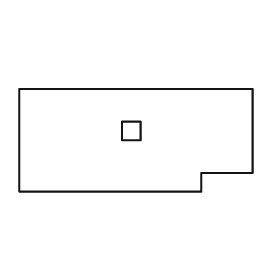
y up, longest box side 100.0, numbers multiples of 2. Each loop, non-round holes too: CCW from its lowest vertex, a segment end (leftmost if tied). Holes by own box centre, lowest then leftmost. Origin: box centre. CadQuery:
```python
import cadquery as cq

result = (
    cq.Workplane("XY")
    .moveTo(-50.0, -22.0)
    .lineTo(28.0, -22.0)
    .lineTo(28.0, -14.0)
    .lineTo(50.0, -14.0)
    .lineTo(50.0, 22.0)
    .lineTo(-50.0, 22.0)
    .close()
    .moveTo(-6.0, 0.0)
    .lineTo(2.0, 0.0)
    .lineTo(2.0, 8.0)
    .lineTo(-6.0, 8.0)
    .close()
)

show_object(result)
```